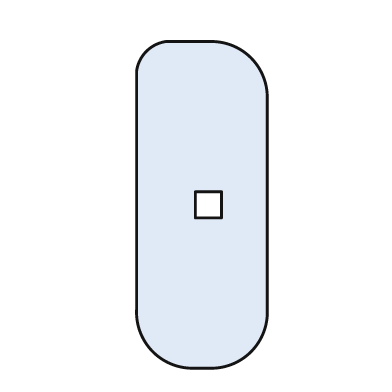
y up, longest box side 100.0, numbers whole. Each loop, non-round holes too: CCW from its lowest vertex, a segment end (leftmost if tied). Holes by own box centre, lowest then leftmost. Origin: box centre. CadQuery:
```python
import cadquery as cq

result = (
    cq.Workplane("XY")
    .moveTo(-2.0, -50.0)
    .lineTo(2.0, -50.0)
    .threePointArc((15.0, -45.0), (20.0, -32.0))
    .lineTo(20.0, 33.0)
    .threePointArc((15.0, 45.0), (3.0, 50.0))
    .lineTo(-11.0, 50.0)
    .threePointArc((-17.0, 47.0), (-20.0, 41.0))
    .lineTo(-20.0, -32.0)
    .threePointArc((-15.0, -45.0), (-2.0, -50.0))
    .close()
    .moveTo(-2.0, -4.0)
    .lineTo(6.0, -4.0)
    .lineTo(6.0, 4.0)
    .lineTo(-2.0, 4.0)
    .close()
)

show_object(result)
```